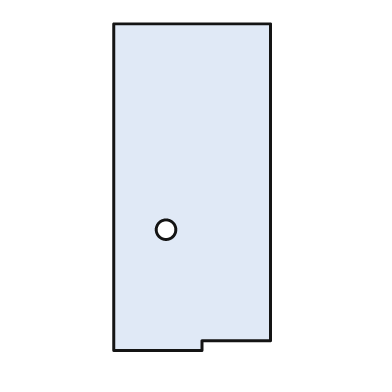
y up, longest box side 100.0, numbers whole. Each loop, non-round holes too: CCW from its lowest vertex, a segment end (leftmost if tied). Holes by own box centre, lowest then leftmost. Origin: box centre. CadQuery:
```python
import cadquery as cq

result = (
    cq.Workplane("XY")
    .moveTo(-24.0, -50.0)
    .lineTo(3.0, -50.0)
    .lineTo(3.0, -47.0)
    .lineTo(24.0, -47.0)
    .lineTo(24.0, 50.0)
    .lineTo(-24.0, 50.0)
    .close()
    .moveTo(-8.0, -13.0)
    .circle(3.0)
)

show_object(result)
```